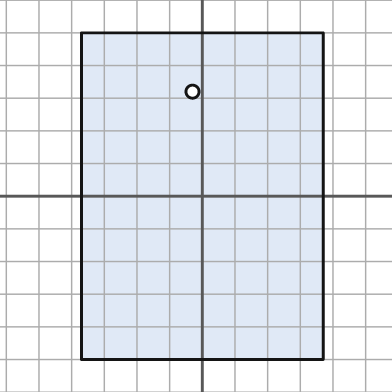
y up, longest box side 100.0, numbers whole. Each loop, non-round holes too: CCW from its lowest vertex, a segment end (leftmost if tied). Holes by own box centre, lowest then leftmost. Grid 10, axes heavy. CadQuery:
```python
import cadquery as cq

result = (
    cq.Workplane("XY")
    .moveTo(-37.0, -50.0)
    .lineTo(37.0, -50.0)
    .lineTo(37.0, 50.0)
    .lineTo(-37.0, 50.0)
    .close()
    .moveTo(-3.0, 32.0)
    .circle(2.0)
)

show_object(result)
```